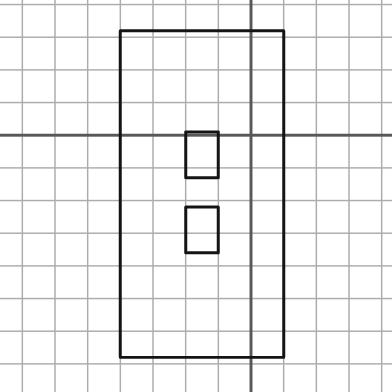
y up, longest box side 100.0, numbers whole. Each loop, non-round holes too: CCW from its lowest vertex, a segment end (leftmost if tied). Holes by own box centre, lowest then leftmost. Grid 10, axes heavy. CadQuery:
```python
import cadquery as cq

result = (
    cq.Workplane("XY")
    .moveTo(-40.0, -68.0)
    .lineTo(10.0, -68.0)
    .lineTo(10.0, 32.0)
    .lineTo(-40.0, 32.0)
    .close()
    .moveTo(-20.0, -36.0)
    .lineTo(-10.0, -36.0)
    .lineTo(-10.0, -22.0)
    .lineTo(-20.0, -22.0)
    .close()
    .moveTo(-20.0, -13.0)
    .lineTo(-10.0, -13.0)
    .lineTo(-10.0, 1.0)
    .lineTo(-20.0, 1.0)
    .close()
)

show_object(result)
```